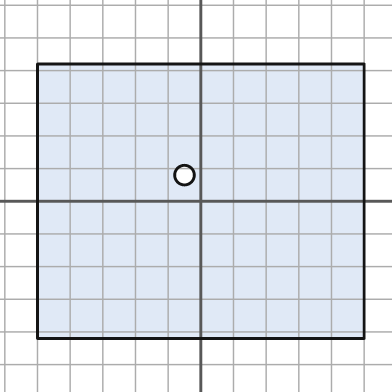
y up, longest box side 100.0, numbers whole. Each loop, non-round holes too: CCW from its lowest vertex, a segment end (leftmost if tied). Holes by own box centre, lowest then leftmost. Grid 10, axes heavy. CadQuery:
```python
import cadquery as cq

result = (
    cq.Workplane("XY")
    .moveTo(-50.0, -42.0)
    .lineTo(50.0, -42.0)
    .lineTo(50.0, 42.0)
    .lineTo(-50.0, 42.0)
    .close()
    .moveTo(-5.0, 8.0)
    .circle(3.0)
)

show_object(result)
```